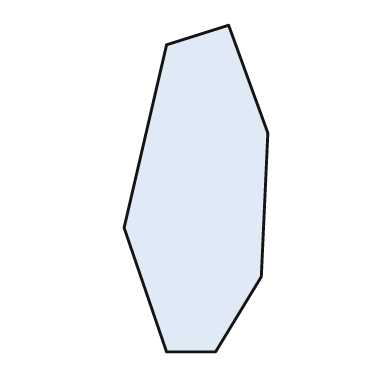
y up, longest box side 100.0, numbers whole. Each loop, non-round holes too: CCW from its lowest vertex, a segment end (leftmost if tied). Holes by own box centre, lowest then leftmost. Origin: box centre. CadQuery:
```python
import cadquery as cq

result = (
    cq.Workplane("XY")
    .moveTo(-9.0, -50.0)
    .lineTo(6.0, -50.0)
    .lineTo(20.0, -27.0)
    .lineTo(22.0, 17.0)
    .lineTo(10.0, 50.0)
    .lineTo(-9.0, 44.0)
    .lineTo(-22.0, -12.0)
    .close()
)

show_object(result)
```